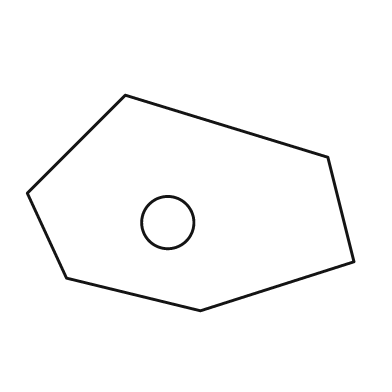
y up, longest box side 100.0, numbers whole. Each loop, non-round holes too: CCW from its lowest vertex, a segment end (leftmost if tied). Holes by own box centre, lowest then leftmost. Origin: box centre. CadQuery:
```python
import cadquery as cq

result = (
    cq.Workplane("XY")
    .moveTo(3.0, -33.0)
    .lineTo(50.0, -18.0)
    .lineTo(42.0, 14.0)
    .lineTo(-20.0, 33.0)
    .lineTo(-50.0, 3.0)
    .lineTo(-38.0, -23.0)
    .close()
    .moveTo(-7.0, -6.0)
    .circle(8.0)
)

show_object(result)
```